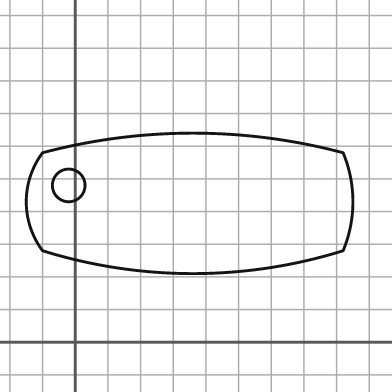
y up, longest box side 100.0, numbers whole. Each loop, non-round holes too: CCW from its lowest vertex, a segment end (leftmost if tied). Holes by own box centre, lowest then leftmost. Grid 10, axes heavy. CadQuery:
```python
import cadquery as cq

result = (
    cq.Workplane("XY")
    .moveTo(-10.0, 28.0)
    .threePointArc((36.0, 21.0), (82.0, 28.0))
    .threePointArc((85.0, 43.0), (82.0, 58.0))
    .threePointArc((36.0, 64.0), (-10.0, 58.0))
    .threePointArc((-15.0, 43.0), (-10.0, 28.0))
    .close()
    .moveTo(-2.0, 48.0)
    .circle(5.0)
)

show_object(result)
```